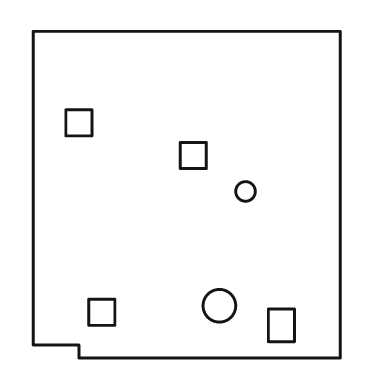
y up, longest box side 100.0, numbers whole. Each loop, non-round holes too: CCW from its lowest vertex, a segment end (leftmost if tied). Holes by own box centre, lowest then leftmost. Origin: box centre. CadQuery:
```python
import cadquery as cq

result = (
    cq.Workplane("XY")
    .moveTo(-33.0, -50.0)
    .lineTo(47.0, -50.0)
    .lineTo(47.0, 50.0)
    .lineTo(-47.0, 50.0)
    .lineTo(-47.0, -46.0)
    .lineTo(-33.0, -46.0)
    .close()
    .moveTo(25.0, -45.0)
    .lineTo(33.0, -45.0)
    .lineTo(33.0, -35.0)
    .lineTo(25.0, -35.0)
    .close()
    .moveTo(-30.0, -40.0)
    .lineTo(-22.0, -40.0)
    .lineTo(-22.0, -32.0)
    .lineTo(-30.0, -32.0)
    .close()
    .moveTo(10.0, -34.0)
    .circle(5.0)
    .moveTo(18.0, 1.0)
    .circle(3.0)
    .moveTo(-2.0, 8.0)
    .lineTo(6.0, 8.0)
    .lineTo(6.0, 16.0)
    .lineTo(-2.0, 16.0)
    .close()
    .moveTo(-37.0, 18.0)
    .lineTo(-29.0, 18.0)
    .lineTo(-29.0, 26.0)
    .lineTo(-37.0, 26.0)
    .close()
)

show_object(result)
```